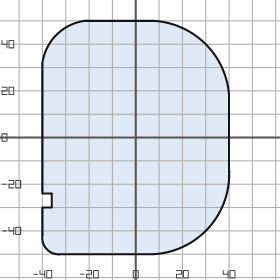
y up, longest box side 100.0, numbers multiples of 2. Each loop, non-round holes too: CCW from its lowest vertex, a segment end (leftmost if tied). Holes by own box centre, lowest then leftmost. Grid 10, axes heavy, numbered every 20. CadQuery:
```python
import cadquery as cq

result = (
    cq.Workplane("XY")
    .moveTo(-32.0, -50.0)
    .lineTo(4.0, -50.0)
    .threePointArc((30.0, -40.0), (40.0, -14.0))
    .lineTo(40.0, 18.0)
    .threePointArc((30.0, 40.0), (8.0, 50.0))
    .lineTo(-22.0, 50.0)
    .threePointArc((-34.0, 44.0), (-40.0, 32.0))
    .lineTo(-40.0, -24.0)
    .lineTo(-36.0, -24.0)
    .lineTo(-36.0, -30.0)
    .lineTo(-40.0, -30.0)
    .lineTo(-40.0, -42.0)
    .threePointArc((-38.0, -48.0), (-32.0, -50.0))
    .close()
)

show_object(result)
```